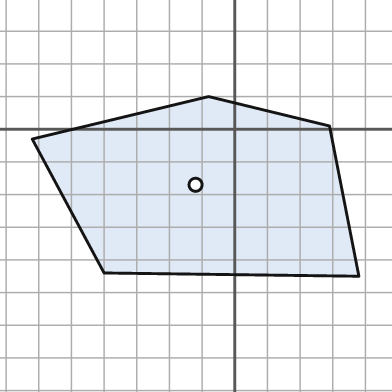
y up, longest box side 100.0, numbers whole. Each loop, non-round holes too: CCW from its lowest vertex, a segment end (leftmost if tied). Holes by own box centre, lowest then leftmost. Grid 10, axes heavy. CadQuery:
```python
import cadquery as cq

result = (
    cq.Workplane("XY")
    .moveTo(38.0, -45.0)
    .lineTo(29.0, 1.0)
    .lineTo(-8.0, 10.0)
    .lineTo(-62.0, -3.0)
    .lineTo(-40.0, -44.0)
    .close()
    .moveTo(-12.0, -17.0)
    .circle(2.0)
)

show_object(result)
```